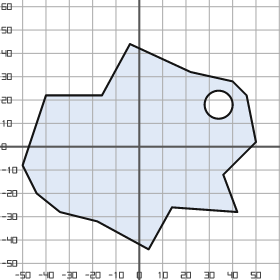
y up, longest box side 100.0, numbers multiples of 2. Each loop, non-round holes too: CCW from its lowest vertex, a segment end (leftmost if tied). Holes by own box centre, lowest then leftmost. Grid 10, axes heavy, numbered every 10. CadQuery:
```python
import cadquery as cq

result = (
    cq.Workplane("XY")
    .moveTo(4.0, -44.0)
    .lineTo(14.0, -26.0)
    .lineTo(42.0, -28.0)
    .lineTo(36.0, -12.0)
    .lineTo(50.0, 2.0)
    .lineTo(46.0, 22.0)
    .lineTo(40.0, 28.0)
    .lineTo(22.0, 32.0)
    .lineTo(-4.0, 44.0)
    .lineTo(-16.0, 22.0)
    .lineTo(-40.0, 22.0)
    .lineTo(-50.0, -8.0)
    .lineTo(-44.0, -20.0)
    .lineTo(-34.0, -28.0)
    .lineTo(-18.0, -32.0)
    .close()
    .moveTo(34.0, 18.0)
    .circle(6.0)
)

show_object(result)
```